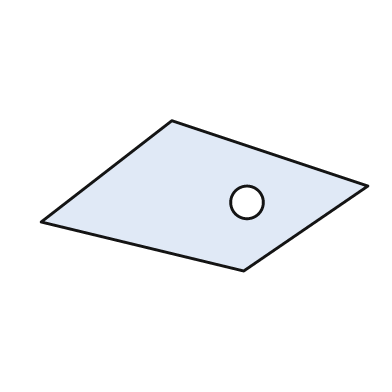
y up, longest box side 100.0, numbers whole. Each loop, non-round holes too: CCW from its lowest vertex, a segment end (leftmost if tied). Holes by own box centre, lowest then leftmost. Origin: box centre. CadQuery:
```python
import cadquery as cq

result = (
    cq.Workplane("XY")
    .moveTo(12.0, -23.0)
    .lineTo(50.0, 3.0)
    .lineTo(-10.0, 23.0)
    .lineTo(-50.0, -8.0)
    .close()
    .moveTo(13.0, -2.0)
    .circle(5.0)
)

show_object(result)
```